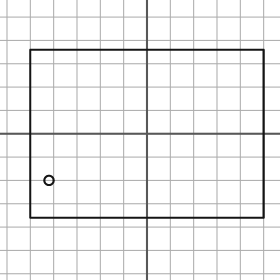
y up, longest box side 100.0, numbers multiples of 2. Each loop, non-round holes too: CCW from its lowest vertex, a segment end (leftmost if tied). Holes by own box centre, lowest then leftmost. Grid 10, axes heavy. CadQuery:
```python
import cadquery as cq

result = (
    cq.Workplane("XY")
    .moveTo(-50.0, -36.0)
    .lineTo(50.0, -36.0)
    .lineTo(50.0, 36.0)
    .lineTo(-50.0, 36.0)
    .close()
    .moveTo(-42.0, -20.0)
    .circle(2.0)
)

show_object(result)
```